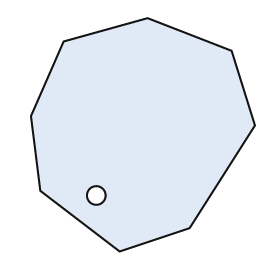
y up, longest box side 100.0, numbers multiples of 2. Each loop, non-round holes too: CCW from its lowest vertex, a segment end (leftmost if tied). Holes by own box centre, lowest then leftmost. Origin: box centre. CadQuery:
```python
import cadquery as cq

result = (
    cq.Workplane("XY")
    .moveTo(-10.0, -50.0)
    .lineTo(20.0, -40.0)
    .lineTo(48.0, 4.0)
    .lineTo(38.0, 36.0)
    .lineTo(2.0, 50.0)
    .lineTo(-34.0, 40.0)
    .lineTo(-48.0, 8.0)
    .lineTo(-44.0, -24.0)
    .close()
    .moveTo(-20.0, -26.0)
    .circle(4.0)
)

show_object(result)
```